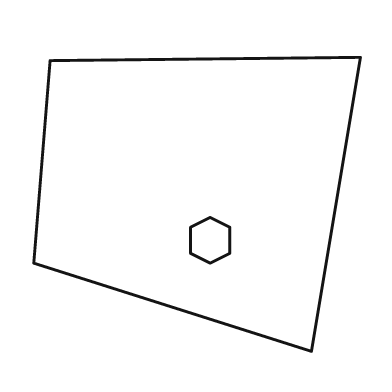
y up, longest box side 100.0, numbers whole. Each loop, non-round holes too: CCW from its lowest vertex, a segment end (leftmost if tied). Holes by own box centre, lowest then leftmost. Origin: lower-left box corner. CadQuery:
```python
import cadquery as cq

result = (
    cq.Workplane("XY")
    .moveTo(85.0, 0.0)
    .lineTo(100.0, 90.0)
    .lineTo(5.0, 89.0)
    .lineTo(0.0, 27.0)
    .close()
    .moveTo(54.0, 27.0)
    .lineTo(60.0, 30.0)
    .lineTo(60.0, 38.0)
    .lineTo(54.0, 41.0)
    .lineTo(48.0, 38.0)
    .lineTo(48.0, 30.0)
    .close()
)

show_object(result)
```